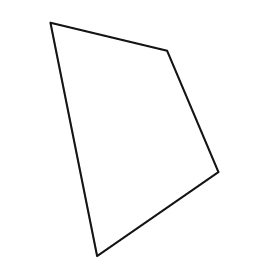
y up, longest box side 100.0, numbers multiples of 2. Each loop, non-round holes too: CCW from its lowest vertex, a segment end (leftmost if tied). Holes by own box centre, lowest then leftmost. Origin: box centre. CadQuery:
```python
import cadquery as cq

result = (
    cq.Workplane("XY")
    .moveTo(-16.0, -50.0)
    .lineTo(36.0, -14.0)
    .lineTo(14.0, 38.0)
    .lineTo(-36.0, 50.0)
    .close()
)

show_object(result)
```